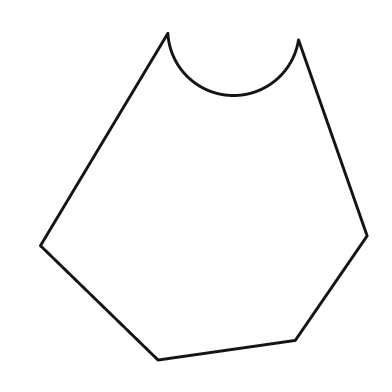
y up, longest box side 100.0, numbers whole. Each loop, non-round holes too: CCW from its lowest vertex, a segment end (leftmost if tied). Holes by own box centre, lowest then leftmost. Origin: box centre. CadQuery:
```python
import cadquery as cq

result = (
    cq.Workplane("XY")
    .moveTo(-14.0, -50.0)
    .lineTo(28.0, -44.0)
    .lineTo(50.0, -12.0)
    .lineTo(29.0, 48.0)
    .threePointArc((8.0, 31.0), (-11.0, 50.0))
    .lineTo(-50.0, -15.0)
    .close()
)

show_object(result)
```